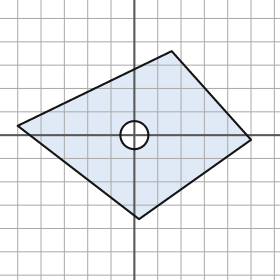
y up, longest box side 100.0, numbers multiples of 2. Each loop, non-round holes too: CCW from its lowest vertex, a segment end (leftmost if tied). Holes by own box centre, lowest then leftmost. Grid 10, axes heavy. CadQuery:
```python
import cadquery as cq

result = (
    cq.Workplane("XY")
    .moveTo(2.0, -36.0)
    .lineTo(50.0, -2.0)
    .lineTo(16.0, 36.0)
    .lineTo(-50.0, 4.0)
    .close()
    .moveTo(0.0, 0.0)
    .circle(6.0)
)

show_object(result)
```